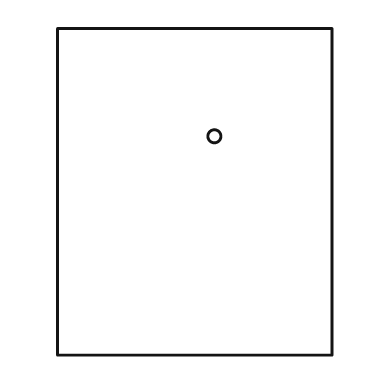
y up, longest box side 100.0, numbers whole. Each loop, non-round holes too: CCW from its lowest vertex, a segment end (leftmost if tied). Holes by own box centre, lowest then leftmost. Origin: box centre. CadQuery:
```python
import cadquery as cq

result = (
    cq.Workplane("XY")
    .moveTo(-42.0, -50.0)
    .lineTo(42.0, -50.0)
    .lineTo(42.0, 50.0)
    .lineTo(-42.0, 50.0)
    .close()
    .moveTo(6.0, 17.0)
    .circle(2.0)
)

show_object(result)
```